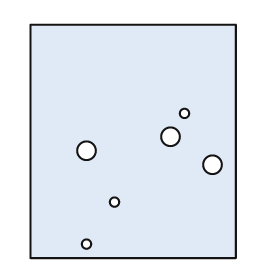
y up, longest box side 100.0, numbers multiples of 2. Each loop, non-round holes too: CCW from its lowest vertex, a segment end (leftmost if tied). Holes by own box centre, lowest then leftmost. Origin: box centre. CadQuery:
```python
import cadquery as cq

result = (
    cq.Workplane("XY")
    .moveTo(-44.0, -50.0)
    .lineTo(44.0, -50.0)
    .lineTo(44.0, 50.0)
    .lineTo(-44.0, 50.0)
    .close()
    .moveTo(-20.0, -44.0)
    .circle(2.0)
    .moveTo(-8.0, -26.0)
    .circle(2.0)
    .moveTo(34.0, -10.0)
    .circle(4.0)
    .moveTo(-20.0, -4.0)
    .circle(4.0)
    .moveTo(16.0, 2.0)
    .circle(4.0)
    .moveTo(22.0, 12.0)
    .circle(2.0)
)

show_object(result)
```